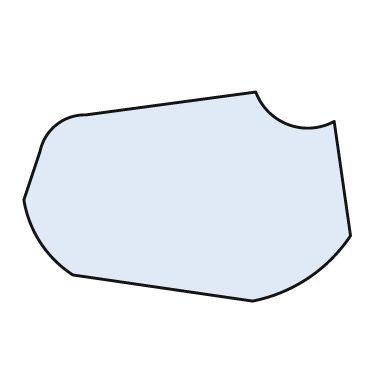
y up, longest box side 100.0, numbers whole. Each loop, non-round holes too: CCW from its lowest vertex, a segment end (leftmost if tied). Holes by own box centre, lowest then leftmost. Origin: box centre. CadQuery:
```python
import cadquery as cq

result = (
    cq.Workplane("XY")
    .moveTo(20.0, -32.0)
    .threePointArc((37.0, -25.0), (50.0, -12.0))
    .lineTo(45.0, 23.0)
    .threePointArc((31.0, 22.0), (21.0, 32.0))
    .lineTo(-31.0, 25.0)
    .threePointArc((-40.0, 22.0), (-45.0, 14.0))
    .lineTo(-50.0, -1.0)
    .threePointArc((-45.0, -14.0), (-35.0, -24.0))
    .close()
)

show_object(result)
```